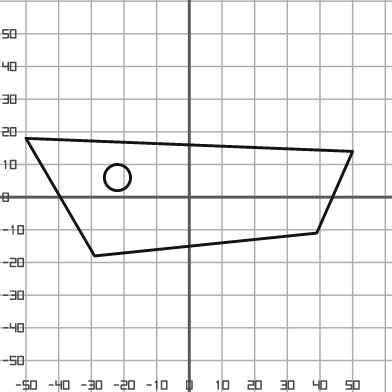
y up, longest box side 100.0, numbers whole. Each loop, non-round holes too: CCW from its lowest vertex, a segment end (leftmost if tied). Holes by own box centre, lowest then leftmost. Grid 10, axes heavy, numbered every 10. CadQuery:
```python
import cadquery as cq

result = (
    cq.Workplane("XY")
    .moveTo(-29.0, -18.0)
    .lineTo(39.0, -11.0)
    .lineTo(50.0, 14.0)
    .lineTo(-50.0, 18.0)
    .close()
    .moveTo(-22.0, 6.0)
    .circle(4.0)
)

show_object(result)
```